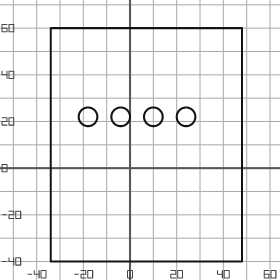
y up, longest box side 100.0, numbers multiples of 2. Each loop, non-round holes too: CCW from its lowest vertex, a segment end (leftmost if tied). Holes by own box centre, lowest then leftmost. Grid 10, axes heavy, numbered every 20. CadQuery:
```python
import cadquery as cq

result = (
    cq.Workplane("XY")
    .moveTo(-34.0, -40.0)
    .lineTo(48.0, -40.0)
    .lineTo(48.0, 60.0)
    .lineTo(-34.0, 60.0)
    .close()
    .moveTo(-18.0, 22.0)
    .circle(4.0)
    .moveTo(-4.0, 22.0)
    .circle(4.0)
    .moveTo(10.0, 22.0)
    .circle(4.0)
    .moveTo(24.0, 22.0)
    .circle(4.0)
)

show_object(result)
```